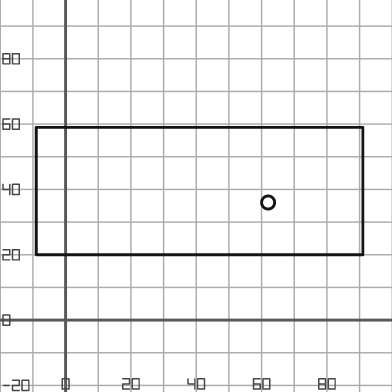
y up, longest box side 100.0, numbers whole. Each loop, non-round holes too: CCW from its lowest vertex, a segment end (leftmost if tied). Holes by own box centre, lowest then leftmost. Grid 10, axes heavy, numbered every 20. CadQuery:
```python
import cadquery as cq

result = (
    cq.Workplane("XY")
    .moveTo(-9.0, 20.0)
    .lineTo(91.0, 20.0)
    .lineTo(91.0, 59.0)
    .lineTo(-9.0, 59.0)
    .close()
    .moveTo(62.0, 36.0)
    .circle(2.0)
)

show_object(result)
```